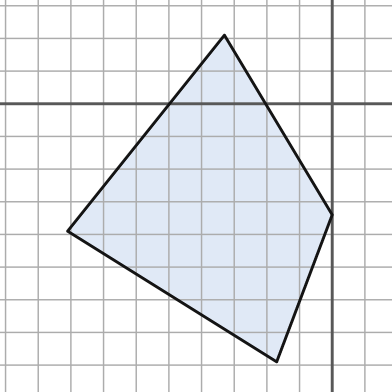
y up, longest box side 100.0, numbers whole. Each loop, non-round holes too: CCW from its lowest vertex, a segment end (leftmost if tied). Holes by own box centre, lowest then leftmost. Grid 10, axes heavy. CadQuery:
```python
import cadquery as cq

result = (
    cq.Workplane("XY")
    .moveTo(-17.0, -79.0)
    .lineTo(0.0, -34.0)
    .lineTo(-33.0, 21.0)
    .lineTo(-81.0, -39.0)
    .close()
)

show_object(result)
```